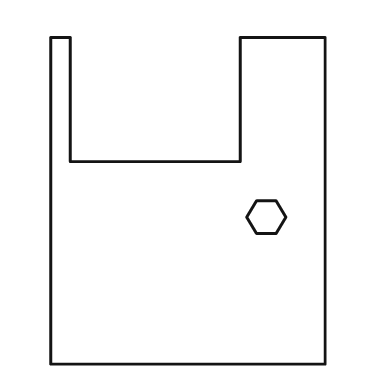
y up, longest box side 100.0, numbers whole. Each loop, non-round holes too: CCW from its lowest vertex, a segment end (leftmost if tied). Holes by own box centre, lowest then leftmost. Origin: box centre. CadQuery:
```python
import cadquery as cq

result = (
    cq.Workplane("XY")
    .moveTo(-42.0, -50.0)
    .lineTo(42.0, -50.0)
    .lineTo(42.0, 50.0)
    .lineTo(16.0, 50.0)
    .lineTo(16.0, 12.0)
    .lineTo(-36.0, 12.0)
    .lineTo(-36.0, 50.0)
    .lineTo(-42.0, 50.0)
    .close()
    .moveTo(21.0, -10.0)
    .lineTo(27.0, -10.0)
    .lineTo(30.0, -5.0)
    .lineTo(27.0, 0.0)
    .lineTo(21.0, 0.0)
    .lineTo(18.0, -5.0)
    .close()
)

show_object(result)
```